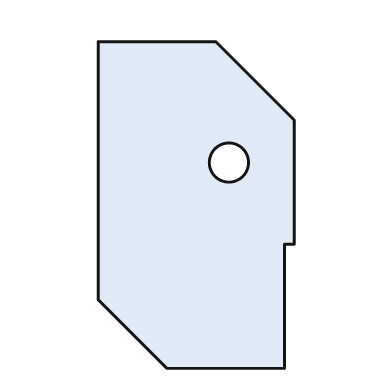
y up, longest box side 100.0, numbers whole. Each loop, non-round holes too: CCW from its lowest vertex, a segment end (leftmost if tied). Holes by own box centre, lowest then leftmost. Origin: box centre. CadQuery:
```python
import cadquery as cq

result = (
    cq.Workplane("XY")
    .moveTo(-9.0, -50.0)
    .lineTo(27.0, -50.0)
    .lineTo(27.0, -12.0)
    .lineTo(30.0, -12.0)
    .lineTo(30.0, 26.0)
    .lineTo(6.0, 50.0)
    .lineTo(-30.0, 50.0)
    .lineTo(-30.0, -29.0)
    .close()
    .moveTo(10.0, 13.0)
    .circle(6.0)
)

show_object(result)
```